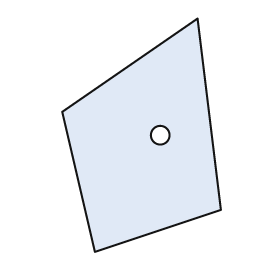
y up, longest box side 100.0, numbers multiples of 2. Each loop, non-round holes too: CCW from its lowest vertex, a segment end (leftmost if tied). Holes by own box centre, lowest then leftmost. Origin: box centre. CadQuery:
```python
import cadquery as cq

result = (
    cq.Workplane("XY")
    .moveTo(-20.0, -50.0)
    .lineTo(34.0, -32.0)
    .lineTo(24.0, 50.0)
    .lineTo(-34.0, 10.0)
    .close()
    .moveTo(8.0, 0.0)
    .circle(4.0)
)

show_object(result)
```